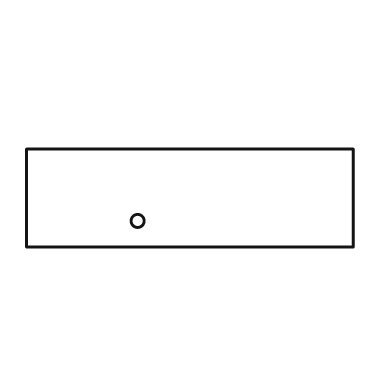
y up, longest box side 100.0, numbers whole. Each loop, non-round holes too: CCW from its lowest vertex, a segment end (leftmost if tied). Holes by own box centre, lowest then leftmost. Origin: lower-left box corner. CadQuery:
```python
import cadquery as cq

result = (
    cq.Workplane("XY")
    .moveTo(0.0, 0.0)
    .lineTo(100.0, 0.0)
    .lineTo(100.0, 30.0)
    .lineTo(0.0, 30.0)
    .close()
    .moveTo(34.0, 8.0)
    .circle(2.0)
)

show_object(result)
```